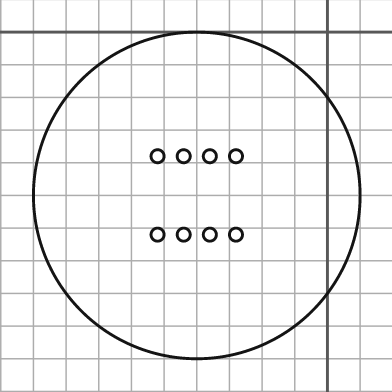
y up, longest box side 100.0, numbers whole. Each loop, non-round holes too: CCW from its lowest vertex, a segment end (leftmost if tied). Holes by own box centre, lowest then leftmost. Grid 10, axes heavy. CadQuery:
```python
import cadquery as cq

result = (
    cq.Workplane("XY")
    .moveTo(-40.0, -50.0)
    .circle(50.0)
    .moveTo(-52.0, -62.0)
    .circle(2.0)
    .moveTo(-44.0, -62.0)
    .circle(2.0)
    .moveTo(-36.0, -62.0)
    .circle(2.0)
    .moveTo(-28.0, -62.0)
    .circle(2.0)
    .moveTo(-52.0, -38.0)
    .circle(2.0)
    .moveTo(-44.0, -38.0)
    .circle(2.0)
    .moveTo(-36.0, -38.0)
    .circle(2.0)
    .moveTo(-28.0, -38.0)
    .circle(2.0)
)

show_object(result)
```